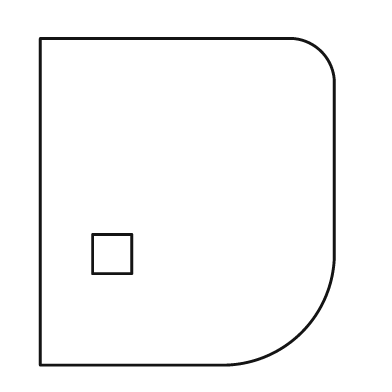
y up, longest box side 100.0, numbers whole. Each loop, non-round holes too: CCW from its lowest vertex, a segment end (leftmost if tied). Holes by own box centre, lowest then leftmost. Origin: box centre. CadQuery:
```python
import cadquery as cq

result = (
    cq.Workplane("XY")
    .moveTo(-45.0, -50.0)
    .lineTo(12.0, -50.0)
    .threePointArc((35.0, -40.0), (45.0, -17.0))
    .lineTo(45.0, 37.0)
    .threePointArc((41.0, 46.0), (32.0, 50.0))
    .lineTo(-45.0, 50.0)
    .close()
    .moveTo(-29.0, -22.0)
    .lineTo(-17.0, -22.0)
    .lineTo(-17.0, -10.0)
    .lineTo(-29.0, -10.0)
    .close()
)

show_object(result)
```